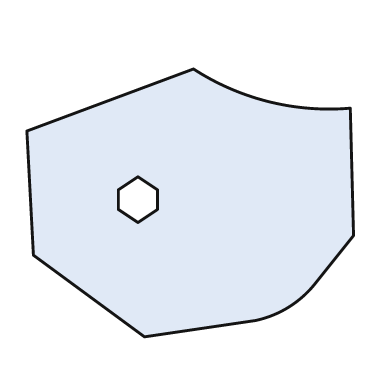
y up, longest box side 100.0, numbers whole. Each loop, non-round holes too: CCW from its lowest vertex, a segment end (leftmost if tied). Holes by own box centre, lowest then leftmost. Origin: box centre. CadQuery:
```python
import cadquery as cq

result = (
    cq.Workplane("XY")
    .moveTo(-14.0, -41.0)
    .lineTo(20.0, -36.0)
    .threePointArc((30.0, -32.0), (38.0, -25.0))
    .lineTo(50.0, -10.0)
    .lineTo(49.0, 29.0)
    .threePointArc((24.0, 31.0), (1.0, 41.0))
    .lineTo(-50.0, 22.0)
    .lineTo(-48.0, -16.0)
    .close()
    .moveTo(-16.0, -6.0)
    .lineTo(-10.0, -2.0)
    .lineTo(-10.0, 4.0)
    .lineTo(-16.0, 8.0)
    .lineTo(-22.0, 4.0)
    .lineTo(-22.0, -2.0)
    .close()
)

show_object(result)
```